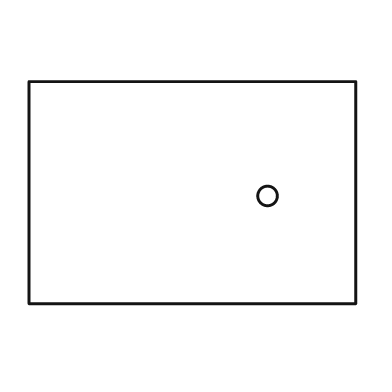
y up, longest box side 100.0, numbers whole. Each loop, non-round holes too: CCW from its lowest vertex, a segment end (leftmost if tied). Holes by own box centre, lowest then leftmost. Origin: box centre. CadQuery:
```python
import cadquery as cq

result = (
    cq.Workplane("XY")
    .moveTo(-50.0, -34.0)
    .lineTo(50.0, -34.0)
    .lineTo(50.0, 34.0)
    .lineTo(-50.0, 34.0)
    .close()
    .moveTo(23.0, -1.0)
    .circle(3.0)
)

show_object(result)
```